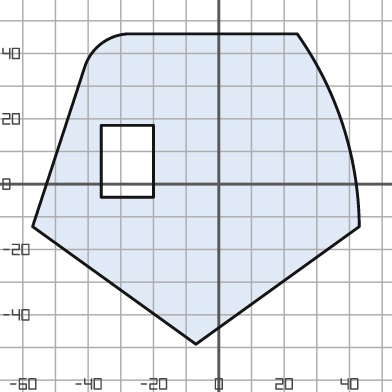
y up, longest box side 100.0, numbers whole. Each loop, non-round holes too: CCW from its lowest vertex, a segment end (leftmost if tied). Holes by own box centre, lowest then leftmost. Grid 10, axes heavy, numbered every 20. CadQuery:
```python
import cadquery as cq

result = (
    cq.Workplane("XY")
    .moveTo(-7.0, -49.0)
    .lineTo(43.0, -13.0)
    .threePointArc((38.0, 18.0), (24.0, 46.0))
    .lineTo(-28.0, 46.0)
    .threePointArc((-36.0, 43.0), (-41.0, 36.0))
    .lineTo(-57.0, -13.0)
    .close()
    .moveTo(-36.0, -4.0)
    .lineTo(-20.0, -4.0)
    .lineTo(-20.0, 18.0)
    .lineTo(-36.0, 18.0)
    .close()
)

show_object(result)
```